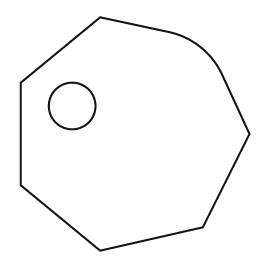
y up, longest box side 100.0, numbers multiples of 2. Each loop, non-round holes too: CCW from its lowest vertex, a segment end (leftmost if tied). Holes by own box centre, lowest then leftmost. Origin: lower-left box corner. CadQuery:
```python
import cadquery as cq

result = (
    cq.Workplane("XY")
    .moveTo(34.0, 0.0)
    .lineTo(78.0, 10.0)
    .lineTo(98.0, 50.0)
    .lineTo(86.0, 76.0)
    .threePointArc((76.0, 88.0), (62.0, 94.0))
    .lineTo(34.0, 100.0)
    .lineTo(0.0, 72.0)
    .lineTo(0.0, 28.0)
    .close()
    .moveTo(22.0, 62.0)
    .circle(10.0)
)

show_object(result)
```